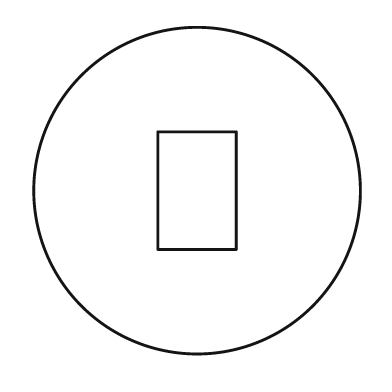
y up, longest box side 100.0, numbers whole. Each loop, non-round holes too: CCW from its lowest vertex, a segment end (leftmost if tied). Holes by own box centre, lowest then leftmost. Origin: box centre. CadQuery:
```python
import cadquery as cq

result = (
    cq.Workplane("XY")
    .moveTo(0.0, 0.0)
    .circle(50.0)
    .moveTo(-12.0, -18.0)
    .lineTo(12.0, -18.0)
    .lineTo(12.0, 18.0)
    .lineTo(-12.0, 18.0)
    .close()
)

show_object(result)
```